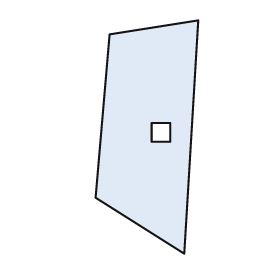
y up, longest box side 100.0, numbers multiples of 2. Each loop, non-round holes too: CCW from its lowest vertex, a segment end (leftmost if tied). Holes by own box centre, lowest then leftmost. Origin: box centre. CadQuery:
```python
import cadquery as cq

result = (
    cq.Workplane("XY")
    .moveTo(16.0, -50.0)
    .lineTo(22.0, 50.0)
    .lineTo(-16.0, 44.0)
    .lineTo(-22.0, -26.0)
    .close()
    .moveTo(2.0, -2.0)
    .lineTo(10.0, -2.0)
    .lineTo(10.0, 6.0)
    .lineTo(2.0, 6.0)
    .close()
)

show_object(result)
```